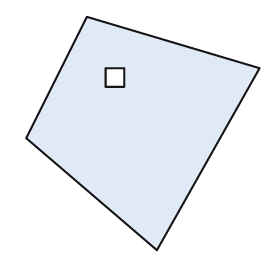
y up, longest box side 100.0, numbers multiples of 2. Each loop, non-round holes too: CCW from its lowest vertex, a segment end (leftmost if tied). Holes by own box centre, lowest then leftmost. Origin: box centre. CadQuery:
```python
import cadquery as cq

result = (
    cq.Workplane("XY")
    .moveTo(6.0, -50.0)
    .lineTo(50.0, 28.0)
    .lineTo(-24.0, 50.0)
    .lineTo(-50.0, -2.0)
    .close()
    .moveTo(-16.0, 20.0)
    .lineTo(-8.0, 20.0)
    .lineTo(-8.0, 28.0)
    .lineTo(-16.0, 28.0)
    .close()
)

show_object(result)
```